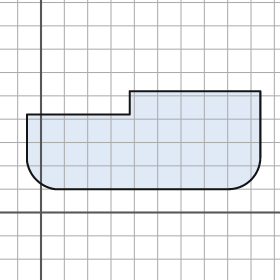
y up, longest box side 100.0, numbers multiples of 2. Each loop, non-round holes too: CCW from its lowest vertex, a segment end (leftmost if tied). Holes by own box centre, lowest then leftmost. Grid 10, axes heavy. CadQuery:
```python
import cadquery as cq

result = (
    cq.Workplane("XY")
    .moveTo(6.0, 10.0)
    .lineTo(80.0, 10.0)
    .threePointArc((90.0, 14.0), (94.0, 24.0))
    .lineTo(94.0, 52.0)
    .lineTo(38.0, 52.0)
    .lineTo(38.0, 42.0)
    .lineTo(-6.0, 42.0)
    .lineTo(-6.0, 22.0)
    .threePointArc((-2.0, 14.0), (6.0, 10.0))
    .close()
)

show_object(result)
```